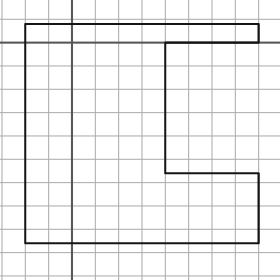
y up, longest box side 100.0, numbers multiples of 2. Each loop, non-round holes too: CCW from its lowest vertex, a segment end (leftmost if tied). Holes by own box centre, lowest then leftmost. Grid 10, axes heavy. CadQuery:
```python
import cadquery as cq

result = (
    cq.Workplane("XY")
    .moveTo(-20.0, -86.0)
    .lineTo(80.0, -86.0)
    .lineTo(80.0, -56.0)
    .lineTo(40.0, -56.0)
    .lineTo(40.0, 0.0)
    .lineTo(80.0, 0.0)
    .lineTo(80.0, 8.0)
    .lineTo(-20.0, 8.0)
    .close()
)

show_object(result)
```